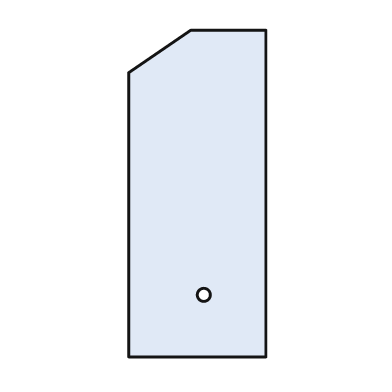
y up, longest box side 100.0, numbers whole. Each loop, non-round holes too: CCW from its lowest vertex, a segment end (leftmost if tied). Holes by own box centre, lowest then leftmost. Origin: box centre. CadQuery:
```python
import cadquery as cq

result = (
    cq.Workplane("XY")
    .moveTo(-21.0, -50.0)
    .lineTo(21.0, -50.0)
    .lineTo(21.0, 50.0)
    .lineTo(-2.0, 50.0)
    .lineTo(-21.0, 37.0)
    .close()
    .moveTo(2.0, -31.0)
    .circle(2.0)
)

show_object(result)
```